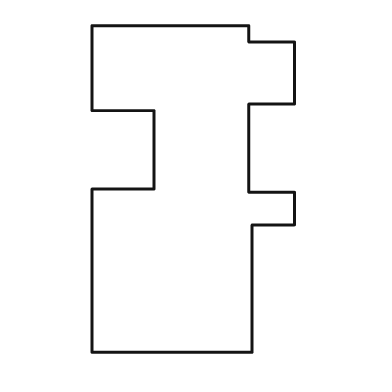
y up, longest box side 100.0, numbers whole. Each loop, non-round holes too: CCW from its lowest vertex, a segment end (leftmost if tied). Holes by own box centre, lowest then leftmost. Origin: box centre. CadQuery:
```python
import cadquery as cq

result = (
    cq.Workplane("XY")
    .moveTo(-31.0, -50.0)
    .lineTo(18.0, -50.0)
    .lineTo(18.0, -11.0)
    .lineTo(31.0, -11.0)
    .lineTo(31.0, -1.0)
    .lineTo(17.0, -1.0)
    .lineTo(17.0, 26.0)
    .lineTo(31.0, 26.0)
    .lineTo(31.0, 45.0)
    .lineTo(17.0, 45.0)
    .lineTo(17.0, 50.0)
    .lineTo(-31.0, 50.0)
    .lineTo(-31.0, 24.0)
    .lineTo(-12.0, 24.0)
    .lineTo(-12.0, 0.0)
    .lineTo(-31.0, 0.0)
    .close()
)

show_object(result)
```